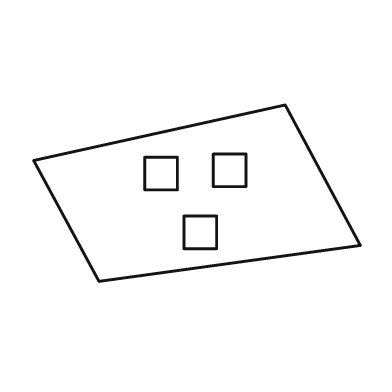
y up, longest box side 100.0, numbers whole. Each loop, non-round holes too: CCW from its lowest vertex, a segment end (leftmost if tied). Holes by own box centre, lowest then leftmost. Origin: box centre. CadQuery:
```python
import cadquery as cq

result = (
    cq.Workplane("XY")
    .moveTo(-30.0, -27.0)
    .lineTo(50.0, -16.0)
    .lineTo(27.0, 27.0)
    .lineTo(-50.0, 10.0)
    .close()
    .moveTo(-4.0, -17.0)
    .lineTo(6.0, -17.0)
    .lineTo(6.0, -7.0)
    .lineTo(-4.0, -7.0)
    .close()
    .moveTo(-16.0, 1.0)
    .lineTo(-6.0, 1.0)
    .lineTo(-6.0, 11.0)
    .lineTo(-16.0, 11.0)
    .close()
    .moveTo(5.0, 2.0)
    .lineTo(15.0, 2.0)
    .lineTo(15.0, 12.0)
    .lineTo(5.0, 12.0)
    .close()
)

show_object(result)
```